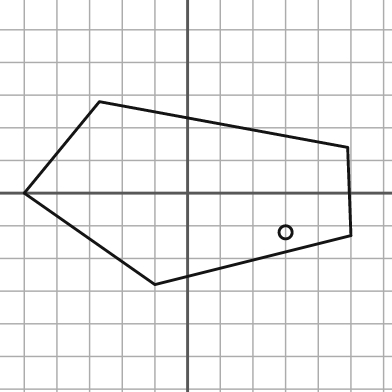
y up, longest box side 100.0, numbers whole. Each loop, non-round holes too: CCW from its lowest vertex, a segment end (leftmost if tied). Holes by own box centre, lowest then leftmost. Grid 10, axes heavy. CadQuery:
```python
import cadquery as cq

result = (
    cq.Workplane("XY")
    .moveTo(-10.0, -28.0)
    .lineTo(50.0, -13.0)
    .lineTo(49.0, 14.0)
    .lineTo(-27.0, 28.0)
    .lineTo(-50.0, 0.0)
    .close()
    .moveTo(30.0, -12.0)
    .circle(2.0)
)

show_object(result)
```